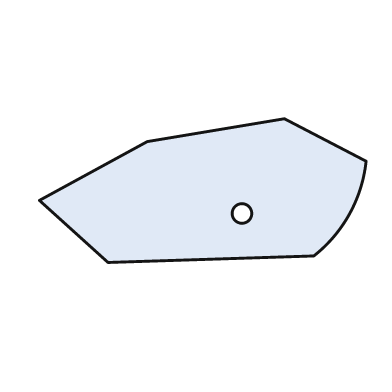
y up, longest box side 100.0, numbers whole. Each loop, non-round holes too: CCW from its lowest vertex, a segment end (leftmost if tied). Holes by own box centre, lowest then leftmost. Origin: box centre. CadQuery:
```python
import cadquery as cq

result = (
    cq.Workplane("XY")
    .moveTo(-29.0, -22.0)
    .lineTo(34.0, -20.0)
    .threePointArc((45.0, -7.0), (50.0, 9.0))
    .lineTo(25.0, 22.0)
    .lineTo(-17.0, 15.0)
    .lineTo(-50.0, -3.0)
    .close()
    .moveTo(12.0, -7.0)
    .circle(3.0)
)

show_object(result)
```